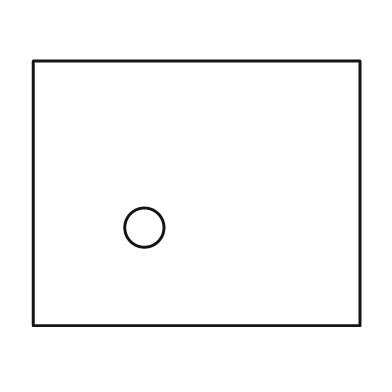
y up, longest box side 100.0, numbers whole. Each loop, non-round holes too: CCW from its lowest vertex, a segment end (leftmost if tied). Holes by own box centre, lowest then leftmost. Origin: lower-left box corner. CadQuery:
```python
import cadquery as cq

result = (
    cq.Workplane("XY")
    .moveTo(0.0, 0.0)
    .lineTo(100.0, 0.0)
    .lineTo(100.0, 81.0)
    .lineTo(0.0, 81.0)
    .close()
    .moveTo(34.0, 30.0)
    .circle(6.0)
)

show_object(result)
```